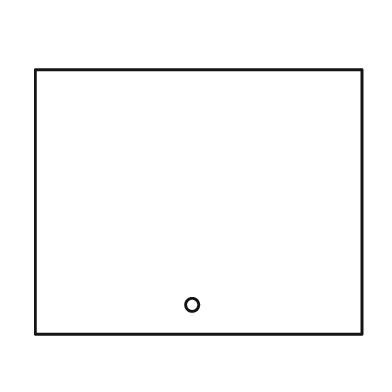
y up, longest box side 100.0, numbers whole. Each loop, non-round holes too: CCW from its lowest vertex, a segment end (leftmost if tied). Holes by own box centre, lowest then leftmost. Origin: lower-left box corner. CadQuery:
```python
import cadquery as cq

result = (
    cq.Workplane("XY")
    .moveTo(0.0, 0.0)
    .lineTo(100.0, 0.0)
    .lineTo(100.0, 81.0)
    .lineTo(0.0, 81.0)
    .close()
    .moveTo(48.0, 9.0)
    .circle(2.0)
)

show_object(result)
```